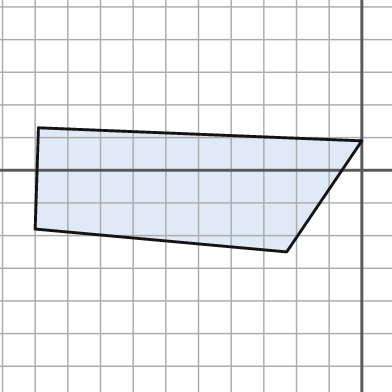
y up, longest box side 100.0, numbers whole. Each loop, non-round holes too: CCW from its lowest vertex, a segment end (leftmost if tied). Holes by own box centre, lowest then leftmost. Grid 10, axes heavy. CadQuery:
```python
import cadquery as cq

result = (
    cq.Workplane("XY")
    .moveTo(-23.0, -25.0)
    .lineTo(0.0, 9.0)
    .lineTo(-99.0, 13.0)
    .lineTo(-100.0, -18.0)
    .close()
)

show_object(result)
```